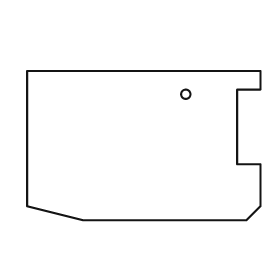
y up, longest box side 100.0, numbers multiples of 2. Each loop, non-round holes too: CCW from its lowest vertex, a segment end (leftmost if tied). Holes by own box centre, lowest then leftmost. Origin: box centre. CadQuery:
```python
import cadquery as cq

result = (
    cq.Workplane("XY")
    .moveTo(-26.0, -32.0)
    .lineTo(44.0, -32.0)
    .lineTo(50.0, -26.0)
    .lineTo(50.0, -8.0)
    .lineTo(40.0, -8.0)
    .lineTo(40.0, 24.0)
    .lineTo(50.0, 24.0)
    .lineTo(50.0, 32.0)
    .lineTo(-50.0, 32.0)
    .lineTo(-50.0, -26.0)
    .close()
    .moveTo(18.0, 22.0)
    .circle(2.0)
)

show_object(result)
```